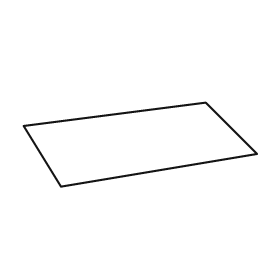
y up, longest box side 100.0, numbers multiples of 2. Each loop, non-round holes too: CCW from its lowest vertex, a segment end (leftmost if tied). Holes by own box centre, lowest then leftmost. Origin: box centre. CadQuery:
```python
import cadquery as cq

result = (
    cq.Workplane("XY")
    .moveTo(-34.0, -18.0)
    .lineTo(50.0, -4.0)
    .lineTo(28.0, 18.0)
    .lineTo(-50.0, 8.0)
    .close()
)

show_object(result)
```